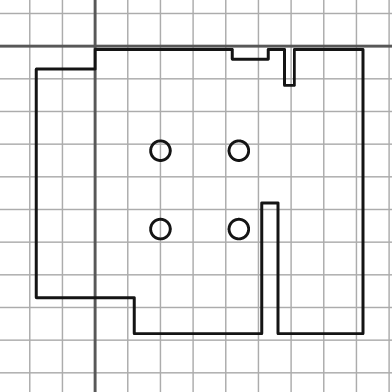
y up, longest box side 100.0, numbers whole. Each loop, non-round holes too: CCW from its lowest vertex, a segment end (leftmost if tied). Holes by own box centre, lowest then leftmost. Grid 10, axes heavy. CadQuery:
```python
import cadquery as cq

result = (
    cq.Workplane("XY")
    .moveTo(12.0, -88.0)
    .lineTo(51.0, -88.0)
    .lineTo(51.0, -48.0)
    .lineTo(56.0, -48.0)
    .lineTo(56.0, -88.0)
    .lineTo(82.0, -88.0)
    .lineTo(82.0, -1.0)
    .lineTo(61.0, -1.0)
    .lineTo(61.0, -12.0)
    .lineTo(58.0, -12.0)
    .lineTo(58.0, -1.0)
    .lineTo(53.0, -1.0)
    .lineTo(53.0, -4.0)
    .lineTo(42.0, -4.0)
    .lineTo(42.0, -1.0)
    .lineTo(0.0, -1.0)
    .lineTo(0.0, -7.0)
    .lineTo(-18.0, -7.0)
    .lineTo(-18.0, -77.0)
    .lineTo(12.0, -77.0)
    .close()
    .moveTo(20.0, -56.0)
    .circle(3.0)
    .moveTo(44.0, -56.0)
    .circle(3.0)
    .moveTo(20.0, -32.0)
    .circle(3.0)
    .moveTo(44.0, -32.0)
    .circle(3.0)
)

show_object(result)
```